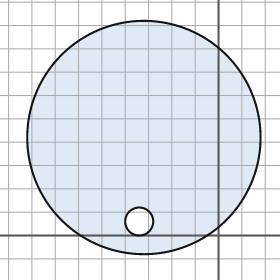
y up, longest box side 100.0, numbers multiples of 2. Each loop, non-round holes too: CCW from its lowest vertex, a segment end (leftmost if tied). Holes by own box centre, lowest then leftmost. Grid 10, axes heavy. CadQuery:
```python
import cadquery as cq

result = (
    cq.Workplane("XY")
    .moveTo(-32.0, 42.0)
    .circle(50.0)
    .moveTo(-34.0, 6.0)
    .circle(6.0)
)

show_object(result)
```